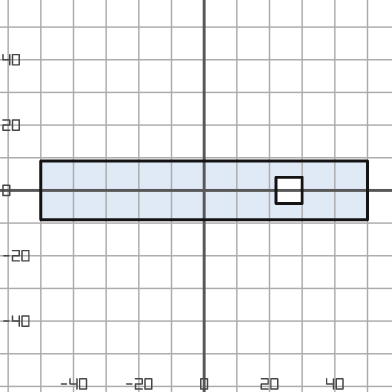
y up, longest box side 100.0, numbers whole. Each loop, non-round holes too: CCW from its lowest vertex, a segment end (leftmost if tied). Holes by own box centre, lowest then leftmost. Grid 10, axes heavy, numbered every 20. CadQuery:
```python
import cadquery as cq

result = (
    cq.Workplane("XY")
    .moveTo(-50.0, -9.0)
    .lineTo(50.0, -9.0)
    .lineTo(50.0, 9.0)
    .lineTo(-50.0, 9.0)
    .close()
    .moveTo(22.0, -4.0)
    .lineTo(30.0, -4.0)
    .lineTo(30.0, 4.0)
    .lineTo(22.0, 4.0)
    .close()
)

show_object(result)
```